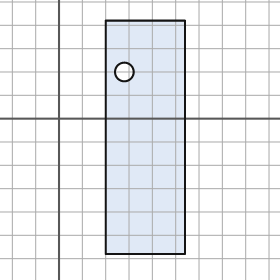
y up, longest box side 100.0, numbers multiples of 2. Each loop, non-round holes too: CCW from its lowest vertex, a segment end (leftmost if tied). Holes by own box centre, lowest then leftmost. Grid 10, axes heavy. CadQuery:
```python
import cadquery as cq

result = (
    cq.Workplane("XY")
    .moveTo(20.0, -58.0)
    .lineTo(54.0, -58.0)
    .lineTo(54.0, 42.0)
    .lineTo(20.0, 42.0)
    .close()
    .moveTo(28.0, 20.0)
    .circle(4.0)
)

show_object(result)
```